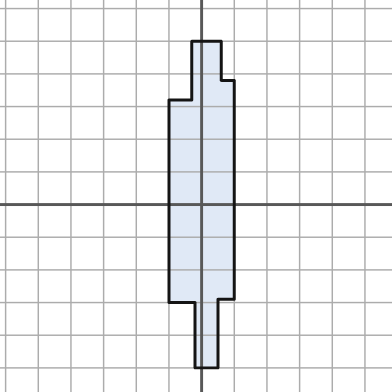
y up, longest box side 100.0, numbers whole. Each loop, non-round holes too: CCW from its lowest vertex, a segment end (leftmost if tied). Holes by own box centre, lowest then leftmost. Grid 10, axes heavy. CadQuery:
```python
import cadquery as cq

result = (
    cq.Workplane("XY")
    .moveTo(-2.0, -50.0)
    .lineTo(5.0, -50.0)
    .lineTo(5.0, -29.0)
    .lineTo(10.0, -29.0)
    .lineTo(10.0, 38.0)
    .lineTo(6.0, 38.0)
    .lineTo(6.0, 50.0)
    .lineTo(-3.0, 50.0)
    .lineTo(-3.0, 32.0)
    .lineTo(-10.0, 32.0)
    .lineTo(-10.0, -30.0)
    .lineTo(-2.0, -30.0)
    .close()
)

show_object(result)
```